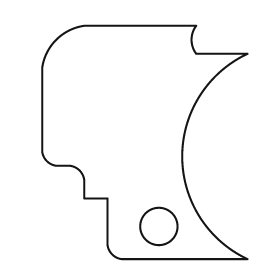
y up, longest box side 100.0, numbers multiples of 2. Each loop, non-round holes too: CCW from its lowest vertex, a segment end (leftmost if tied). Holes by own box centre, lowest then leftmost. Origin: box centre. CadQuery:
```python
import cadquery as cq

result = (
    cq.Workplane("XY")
    .moveTo(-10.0, -50.0)
    .lineTo(44.0, -50.0)
    .threePointArc((16.0, -6.0), (44.0, 38.0))
    .lineTo(22.0, 38.0)
    .threePointArc((20.0, 44.0), (22.0, 50.0))
    .lineTo(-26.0, 50.0)
    .threePointArc((-38.0, 44.0), (-44.0, 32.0))
    .lineTo(-44.0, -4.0)
    .threePointArc((-42.0, -8.0), (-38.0, -10.0))
    .lineTo(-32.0, -10.0)
    .threePointArc((-28.0, -12.0), (-26.0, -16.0))
    .lineTo(-26.0, -24.0)
    .lineTo(-16.0, -24.0)
    .lineTo(-16.0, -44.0)
    .threePointArc((-14.0, -48.0), (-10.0, -50.0))
    .close()
    .moveTo(6.0, -36.0)
    .circle(8.0)
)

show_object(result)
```